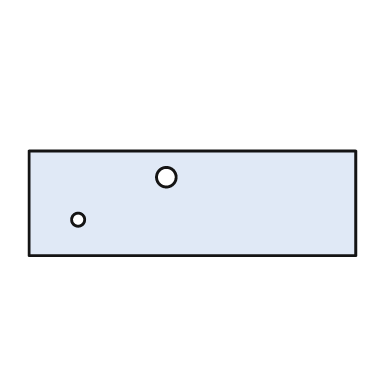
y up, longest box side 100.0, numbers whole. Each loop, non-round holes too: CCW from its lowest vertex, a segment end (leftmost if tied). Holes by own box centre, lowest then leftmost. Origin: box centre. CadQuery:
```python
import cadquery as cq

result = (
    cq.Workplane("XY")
    .moveTo(-50.0, -16.0)
    .lineTo(50.0, -16.0)
    .lineTo(50.0, 16.0)
    .lineTo(-50.0, 16.0)
    .close()
    .moveTo(-35.0, -5.0)
    .circle(2.0)
    .moveTo(-8.0, 8.0)
    .circle(3.0)
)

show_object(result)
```